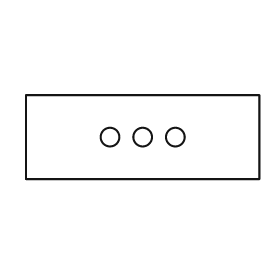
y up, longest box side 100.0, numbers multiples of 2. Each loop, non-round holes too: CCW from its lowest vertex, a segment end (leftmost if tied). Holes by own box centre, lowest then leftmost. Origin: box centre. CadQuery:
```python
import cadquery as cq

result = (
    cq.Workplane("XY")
    .moveTo(-50.0, -18.0)
    .lineTo(50.0, -18.0)
    .lineTo(50.0, 18.0)
    .lineTo(-50.0, 18.0)
    .close()
    .moveTo(-14.0, 0.0)
    .circle(4.0)
    .moveTo(0.0, 0.0)
    .circle(4.0)
    .moveTo(14.0, 0.0)
    .circle(4.0)
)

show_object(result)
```